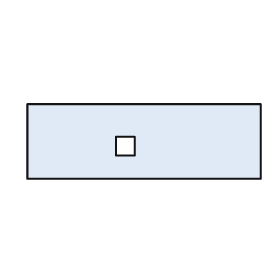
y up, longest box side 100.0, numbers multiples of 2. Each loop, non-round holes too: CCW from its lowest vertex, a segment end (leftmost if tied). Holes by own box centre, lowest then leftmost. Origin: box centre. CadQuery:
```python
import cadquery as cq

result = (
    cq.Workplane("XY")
    .moveTo(-50.0, -16.0)
    .lineTo(50.0, -16.0)
    .lineTo(50.0, 16.0)
    .lineTo(-50.0, 16.0)
    .close()
    .moveTo(-12.0, -6.0)
    .lineTo(-4.0, -6.0)
    .lineTo(-4.0, 2.0)
    .lineTo(-12.0, 2.0)
    .close()
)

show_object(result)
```